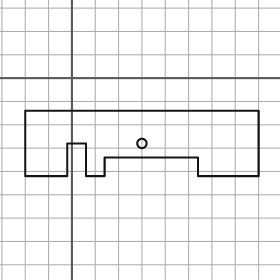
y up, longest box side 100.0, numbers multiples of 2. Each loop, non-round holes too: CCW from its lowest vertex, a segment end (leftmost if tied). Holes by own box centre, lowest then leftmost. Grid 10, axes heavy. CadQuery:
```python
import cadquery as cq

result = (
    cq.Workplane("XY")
    .moveTo(-20.0, -42.0)
    .lineTo(-2.0, -42.0)
    .lineTo(-2.0, -28.0)
    .lineTo(6.0, -28.0)
    .lineTo(6.0, -42.0)
    .lineTo(14.0, -42.0)
    .lineTo(14.0, -34.0)
    .lineTo(54.0, -34.0)
    .lineTo(54.0, -42.0)
    .lineTo(80.0, -42.0)
    .lineTo(80.0, -14.0)
    .lineTo(-20.0, -14.0)
    .close()
    .moveTo(30.0, -28.0)
    .circle(2.0)
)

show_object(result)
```